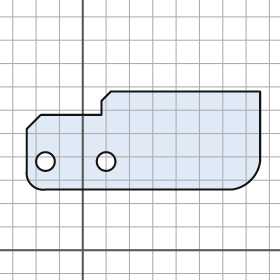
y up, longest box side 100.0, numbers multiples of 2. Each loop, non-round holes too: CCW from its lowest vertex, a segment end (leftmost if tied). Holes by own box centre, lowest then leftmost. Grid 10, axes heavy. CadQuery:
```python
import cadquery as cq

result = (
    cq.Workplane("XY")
    .moveTo(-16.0, 26.0)
    .lineTo(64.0, 26.0)
    .threePointArc((72.0, 30.0), (76.0, 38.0))
    .lineTo(76.0, 68.0)
    .lineTo(12.0, 68.0)
    .lineTo(8.0, 64.0)
    .lineTo(8.0, 58.0)
    .lineTo(-18.0, 58.0)
    .lineTo(-24.0, 52.0)
    .lineTo(-24.0, 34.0)
    .threePointArc((-22.0, 28.0), (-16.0, 26.0))
    .close()
    .moveTo(-16.0, 38.0)
    .circle(4.0)
    .moveTo(10.0, 38.0)
    .circle(4.0)
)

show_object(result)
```